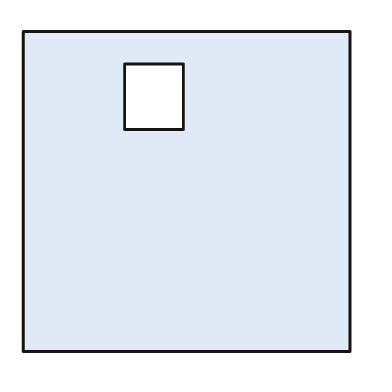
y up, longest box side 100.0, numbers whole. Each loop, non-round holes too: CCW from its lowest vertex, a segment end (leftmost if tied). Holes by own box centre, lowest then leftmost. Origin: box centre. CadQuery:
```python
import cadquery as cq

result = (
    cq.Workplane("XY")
    .moveTo(-50.0, -49.0)
    .lineTo(50.0, -49.0)
    .lineTo(50.0, 49.0)
    .lineTo(-50.0, 49.0)
    .close()
    .moveTo(-19.0, 19.0)
    .lineTo(-1.0, 19.0)
    .lineTo(-1.0, 39.0)
    .lineTo(-19.0, 39.0)
    .close()
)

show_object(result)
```